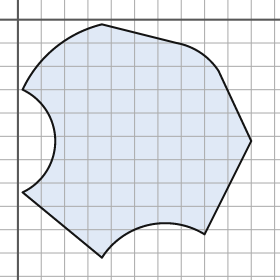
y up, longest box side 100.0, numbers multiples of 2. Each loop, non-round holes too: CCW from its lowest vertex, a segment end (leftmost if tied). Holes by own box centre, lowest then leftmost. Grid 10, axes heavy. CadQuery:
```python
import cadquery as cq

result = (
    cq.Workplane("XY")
    .moveTo(36.0, -102.0)
    .threePointArc((56.0, -88.0), (80.0, -92.0))
    .lineTo(100.0, -52.0)
    .lineTo(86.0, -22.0)
    .threePointArc((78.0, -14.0), (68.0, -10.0))
    .lineTo(36.0, -2.0)
    .threePointArc((16.0, -12.0), (2.0, -30.0))
    .threePointArc((16.0, -52.0), (2.0, -74.0))
    .close()
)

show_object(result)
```